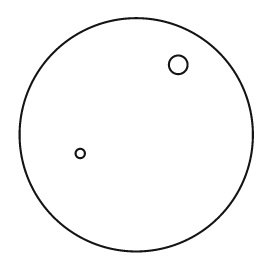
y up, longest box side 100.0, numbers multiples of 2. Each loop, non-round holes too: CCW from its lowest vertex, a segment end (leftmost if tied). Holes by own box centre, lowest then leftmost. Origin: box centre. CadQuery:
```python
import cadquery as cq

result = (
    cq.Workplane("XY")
    .moveTo(0.0, 0.0)
    .circle(50.0)
    .moveTo(-24.0, -8.0)
    .circle(2.0)
    .moveTo(18.0, 30.0)
    .circle(4.0)
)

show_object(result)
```